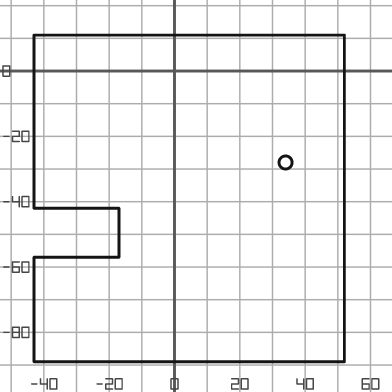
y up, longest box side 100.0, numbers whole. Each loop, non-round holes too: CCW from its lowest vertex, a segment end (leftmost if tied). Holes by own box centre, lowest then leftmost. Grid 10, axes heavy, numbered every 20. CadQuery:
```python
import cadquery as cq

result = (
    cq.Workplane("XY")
    .moveTo(-43.0, -89.0)
    .lineTo(52.0, -89.0)
    .lineTo(52.0, 11.0)
    .lineTo(-43.0, 11.0)
    .lineTo(-43.0, -42.0)
    .lineTo(-17.0, -42.0)
    .lineTo(-17.0, -57.0)
    .lineTo(-43.0, -57.0)
    .close()
    .moveTo(34.0, -28.0)
    .circle(2.0)
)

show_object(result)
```